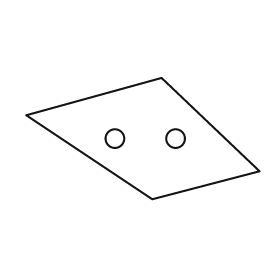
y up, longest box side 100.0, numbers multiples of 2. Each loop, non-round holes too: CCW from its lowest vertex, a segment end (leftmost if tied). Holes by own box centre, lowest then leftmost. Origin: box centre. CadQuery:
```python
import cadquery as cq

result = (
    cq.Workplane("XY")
    .moveTo(4.0, -26.0)
    .lineTo(50.0, -14.0)
    .lineTo(8.0, 26.0)
    .lineTo(-50.0, 10.0)
    .close()
    .moveTo(-12.0, 0.0)
    .circle(4.0)
    .moveTo(14.0, 0.0)
    .circle(4.0)
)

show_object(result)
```